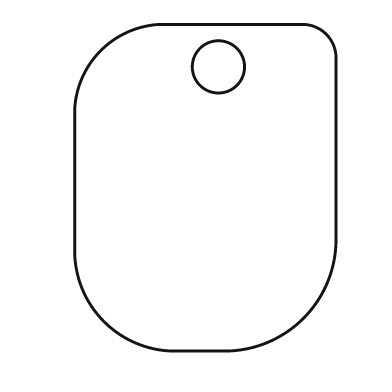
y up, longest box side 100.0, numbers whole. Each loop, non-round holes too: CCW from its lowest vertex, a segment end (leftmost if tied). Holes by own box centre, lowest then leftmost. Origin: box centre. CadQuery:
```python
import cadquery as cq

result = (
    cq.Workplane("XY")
    .moveTo(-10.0, -50.0)
    .lineTo(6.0, -50.0)
    .threePointArc((30.0, -40.0), (40.0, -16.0))
    .lineTo(40.0, 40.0)
    .threePointArc((37.0, 47.0), (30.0, 50.0))
    .lineTo(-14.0, 50.0)
    .threePointArc((-32.0, 42.0), (-40.0, 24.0))
    .lineTo(-40.0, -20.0)
    .threePointArc((-31.0, -41.0), (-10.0, -50.0))
    .close()
    .moveTo(4.0, 37.0)
    .circle(8.0)
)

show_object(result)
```